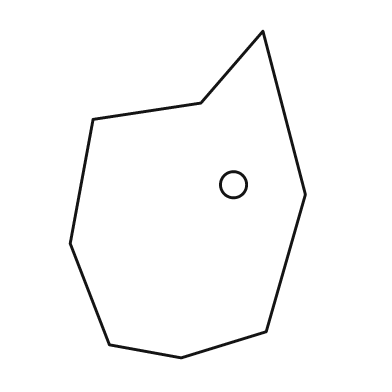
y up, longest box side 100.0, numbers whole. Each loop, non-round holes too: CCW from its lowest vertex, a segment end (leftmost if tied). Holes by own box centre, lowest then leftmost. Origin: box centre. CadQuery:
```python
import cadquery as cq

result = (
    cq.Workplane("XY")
    .moveTo(-2.0, -50.0)
    .lineTo(24.0, -42.0)
    .lineTo(36.0, 0.0)
    .lineTo(23.0, 50.0)
    .lineTo(4.0, 28.0)
    .lineTo(-29.0, 23.0)
    .lineTo(-36.0, -15.0)
    .lineTo(-24.0, -46.0)
    .close()
    .moveTo(14.0, 3.0)
    .circle(4.0)
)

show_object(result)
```